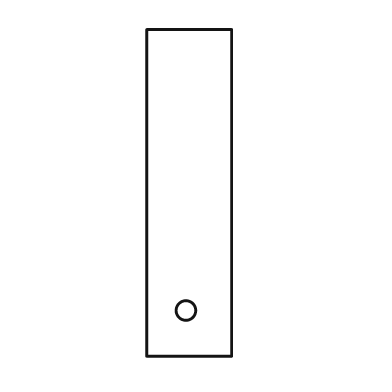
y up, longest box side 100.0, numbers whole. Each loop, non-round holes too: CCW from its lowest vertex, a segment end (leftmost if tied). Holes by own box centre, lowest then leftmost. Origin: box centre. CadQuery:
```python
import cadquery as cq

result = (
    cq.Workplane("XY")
    .moveTo(-13.0, -50.0)
    .lineTo(13.0, -50.0)
    .lineTo(13.0, 50.0)
    .lineTo(-13.0, 50.0)
    .close()
    .moveTo(-1.0, -36.0)
    .circle(3.0)
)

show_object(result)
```